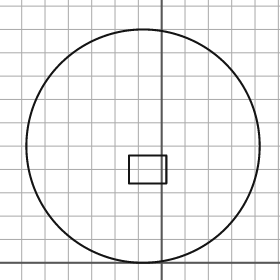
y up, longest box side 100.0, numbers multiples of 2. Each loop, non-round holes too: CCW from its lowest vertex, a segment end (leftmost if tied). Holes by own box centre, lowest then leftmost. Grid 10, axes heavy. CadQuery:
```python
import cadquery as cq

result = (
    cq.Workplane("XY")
    .moveTo(-8.0, 50.0)
    .circle(50.0)
    .moveTo(-14.0, 34.0)
    .lineTo(2.0, 34.0)
    .lineTo(2.0, 46.0)
    .lineTo(-14.0, 46.0)
    .close()
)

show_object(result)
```